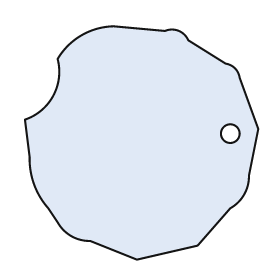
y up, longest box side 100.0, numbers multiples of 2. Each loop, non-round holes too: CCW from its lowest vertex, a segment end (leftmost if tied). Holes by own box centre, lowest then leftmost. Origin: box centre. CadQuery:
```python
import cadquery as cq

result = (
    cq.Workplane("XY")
    .moveTo(-2.0, -50.0)
    .lineTo(24.0, -44.0)
    .lineTo(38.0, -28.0)
    .threePointArc((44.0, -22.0), (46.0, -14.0))
    .lineTo(50.0, 6.0)
    .lineTo(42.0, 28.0)
    .threePointArc((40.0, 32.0), (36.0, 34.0))
    .lineTo(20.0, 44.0)
    .threePointArc((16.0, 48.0), (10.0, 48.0))
    .lineTo(-12.0, 50.0)
    .threePointArc((-26.0, 46.0), (-36.0, 36.0))
    .threePointArc((-38.0, 20.0), (-50.0, 10.0))
    .lineTo(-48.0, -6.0)
    .threePointArc((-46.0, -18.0), (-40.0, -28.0))
    .lineTo(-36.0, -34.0)
    .threePointArc((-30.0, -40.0), (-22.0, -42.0))
    .close()
    .moveTo(38.0, 4.0)
    .circle(4.0)
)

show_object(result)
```